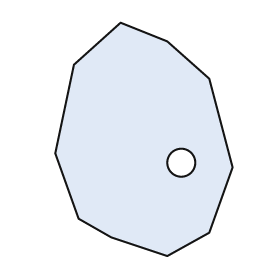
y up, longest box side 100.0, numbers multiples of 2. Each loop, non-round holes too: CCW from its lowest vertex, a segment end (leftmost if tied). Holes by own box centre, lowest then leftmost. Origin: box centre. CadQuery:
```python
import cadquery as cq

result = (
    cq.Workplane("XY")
    .moveTo(10.0, -50.0)
    .lineTo(28.0, -40.0)
    .lineTo(38.0, -12.0)
    .lineTo(28.0, 26.0)
    .lineTo(10.0, 42.0)
    .lineTo(-10.0, 50.0)
    .lineTo(-30.0, 32.0)
    .lineTo(-38.0, -6.0)
    .lineTo(-28.0, -34.0)
    .lineTo(-14.0, -42.0)
    .close()
    .moveTo(16.0, -10.0)
    .circle(6.0)
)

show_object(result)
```